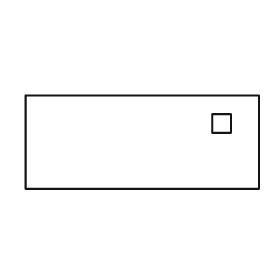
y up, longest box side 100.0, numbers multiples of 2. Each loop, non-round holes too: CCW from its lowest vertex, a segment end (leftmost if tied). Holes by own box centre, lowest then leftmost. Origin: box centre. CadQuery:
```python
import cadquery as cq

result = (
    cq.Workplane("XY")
    .moveTo(-50.0, -20.0)
    .lineTo(50.0, -20.0)
    .lineTo(50.0, 20.0)
    .lineTo(-50.0, 20.0)
    .close()
    .moveTo(30.0, 4.0)
    .lineTo(38.0, 4.0)
    .lineTo(38.0, 12.0)
    .lineTo(30.0, 12.0)
    .close()
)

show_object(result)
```